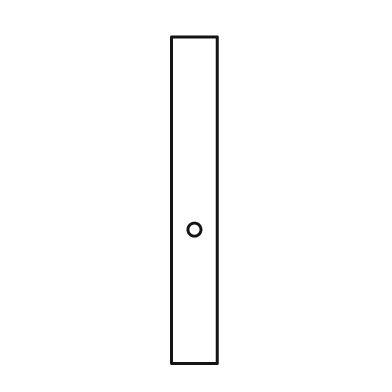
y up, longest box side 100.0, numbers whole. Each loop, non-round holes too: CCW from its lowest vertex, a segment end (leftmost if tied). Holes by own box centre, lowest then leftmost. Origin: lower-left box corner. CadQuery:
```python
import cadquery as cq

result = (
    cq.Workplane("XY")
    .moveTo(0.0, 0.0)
    .lineTo(14.0, 0.0)
    .lineTo(14.0, 100.0)
    .lineTo(0.0, 100.0)
    .close()
    .moveTo(7.0, 41.0)
    .circle(2.0)
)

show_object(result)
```